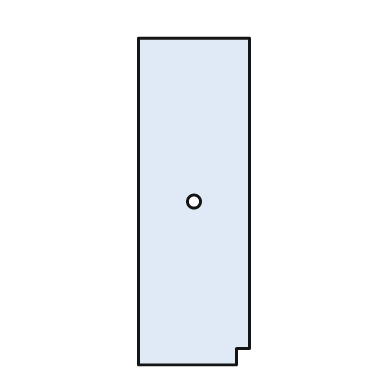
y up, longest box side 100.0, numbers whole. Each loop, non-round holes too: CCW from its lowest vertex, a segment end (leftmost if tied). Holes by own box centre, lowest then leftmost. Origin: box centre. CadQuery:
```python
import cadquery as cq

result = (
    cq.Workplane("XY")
    .moveTo(-17.0, -50.0)
    .lineTo(13.0, -50.0)
    .lineTo(13.0, -45.0)
    .lineTo(17.0, -45.0)
    .lineTo(17.0, 50.0)
    .lineTo(-17.0, 50.0)
    .close()
    .moveTo(0.0, 0.0)
    .circle(2.0)
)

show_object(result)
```